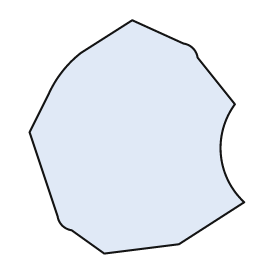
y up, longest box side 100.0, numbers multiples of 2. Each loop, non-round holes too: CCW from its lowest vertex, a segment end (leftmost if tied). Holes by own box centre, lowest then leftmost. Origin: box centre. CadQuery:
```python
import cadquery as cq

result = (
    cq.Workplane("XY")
    .moveTo(-14.0, -50.0)
    .lineTo(18.0, -46.0)
    .lineTo(46.0, -28.0)
    .threePointArc((36.0, -8.0), (42.0, 14.0))
    .lineTo(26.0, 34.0)
    .threePointArc((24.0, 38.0), (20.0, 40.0))
    .lineTo(-2.0, 50.0)
    .lineTo(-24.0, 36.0)
    .threePointArc((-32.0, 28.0), (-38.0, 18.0))
    .lineTo(-46.0, 2.0)
    .lineTo(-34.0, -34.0)
    .threePointArc((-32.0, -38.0), (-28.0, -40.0))
    .close()
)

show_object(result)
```